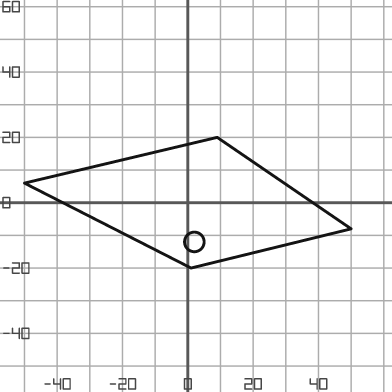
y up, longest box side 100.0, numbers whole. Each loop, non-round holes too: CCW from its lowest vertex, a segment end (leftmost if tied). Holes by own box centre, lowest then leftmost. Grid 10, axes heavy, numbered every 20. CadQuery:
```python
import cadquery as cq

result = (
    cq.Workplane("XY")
    .moveTo(1.0, -20.0)
    .lineTo(50.0, -8.0)
    .lineTo(9.0, 20.0)
    .lineTo(-50.0, 6.0)
    .close()
    .moveTo(2.0, -12.0)
    .circle(3.0)
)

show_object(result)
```